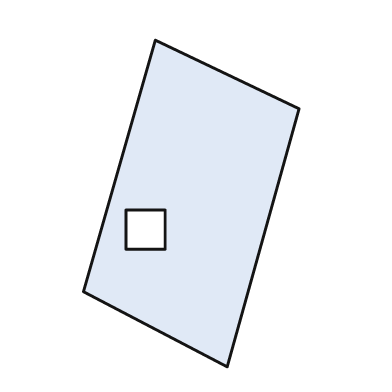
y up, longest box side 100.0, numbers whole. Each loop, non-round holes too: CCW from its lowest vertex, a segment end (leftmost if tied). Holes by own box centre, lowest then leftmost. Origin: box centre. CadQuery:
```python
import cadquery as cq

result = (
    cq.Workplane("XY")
    .moveTo(11.0, -50.0)
    .lineTo(33.0, 29.0)
    .lineTo(-11.0, 50.0)
    .lineTo(-33.0, -27.0)
    .close()
    .moveTo(-20.0, -14.0)
    .lineTo(-8.0, -14.0)
    .lineTo(-8.0, -2.0)
    .lineTo(-20.0, -2.0)
    .close()
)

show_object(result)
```